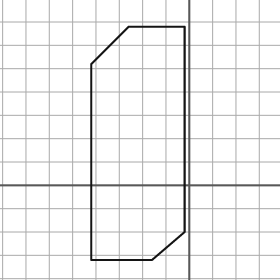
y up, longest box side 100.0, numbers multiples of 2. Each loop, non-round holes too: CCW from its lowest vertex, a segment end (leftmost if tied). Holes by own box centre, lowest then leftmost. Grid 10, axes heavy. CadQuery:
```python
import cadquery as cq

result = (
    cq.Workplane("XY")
    .moveTo(-42.0, -32.0)
    .lineTo(-16.0, -32.0)
    .lineTo(-2.0, -20.0)
    .lineTo(-2.0, 68.0)
    .lineTo(-26.0, 68.0)
    .lineTo(-42.0, 52.0)
    .close()
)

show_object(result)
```